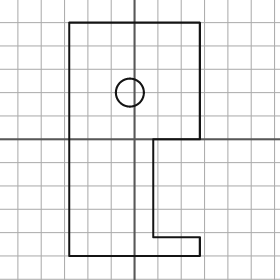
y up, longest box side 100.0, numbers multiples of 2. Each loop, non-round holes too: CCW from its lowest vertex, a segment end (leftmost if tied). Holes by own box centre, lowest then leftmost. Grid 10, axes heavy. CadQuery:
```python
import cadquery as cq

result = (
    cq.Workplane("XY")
    .moveTo(-28.0, -50.0)
    .lineTo(28.0, -50.0)
    .lineTo(28.0, -42.0)
    .lineTo(8.0, -42.0)
    .lineTo(8.0, 0.0)
    .lineTo(28.0, 0.0)
    .lineTo(28.0, 50.0)
    .lineTo(-28.0, 50.0)
    .close()
    .moveTo(-2.0, 20.0)
    .circle(6.0)
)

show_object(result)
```